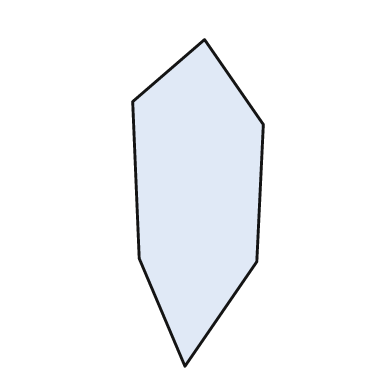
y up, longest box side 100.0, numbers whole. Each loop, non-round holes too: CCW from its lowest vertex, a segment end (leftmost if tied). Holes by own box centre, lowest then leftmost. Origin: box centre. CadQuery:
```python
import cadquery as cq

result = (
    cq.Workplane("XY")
    .moveTo(-4.0, -50.0)
    .lineTo(18.0, -18.0)
    .lineTo(20.0, 24.0)
    .lineTo(2.0, 50.0)
    .lineTo(-20.0, 31.0)
    .lineTo(-18.0, -17.0)
    .close()
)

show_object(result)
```